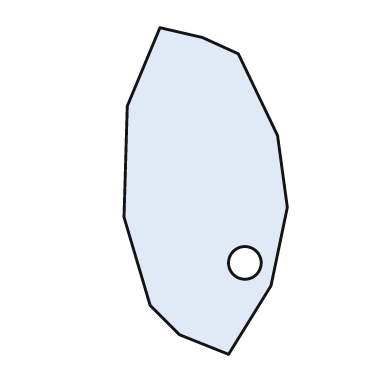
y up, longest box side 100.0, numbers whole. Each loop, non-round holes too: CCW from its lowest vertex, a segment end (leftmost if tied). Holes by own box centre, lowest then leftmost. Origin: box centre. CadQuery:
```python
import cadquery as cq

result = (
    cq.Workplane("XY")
    .moveTo(7.0, -50.0)
    .lineTo(20.0, -29.0)
    .lineTo(25.0, -5.0)
    .lineTo(22.0, 17.0)
    .lineTo(10.0, 42.0)
    .lineTo(-1.0, 47.0)
    .lineTo(-14.0, 50.0)
    .lineTo(-24.0, 26.0)
    .lineTo(-25.0, -8.0)
    .lineTo(-17.0, -35.0)
    .lineTo(-8.0, -44.0)
    .close()
    .moveTo(12.0, -22.0)
    .circle(5.0)
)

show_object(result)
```